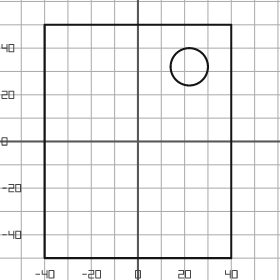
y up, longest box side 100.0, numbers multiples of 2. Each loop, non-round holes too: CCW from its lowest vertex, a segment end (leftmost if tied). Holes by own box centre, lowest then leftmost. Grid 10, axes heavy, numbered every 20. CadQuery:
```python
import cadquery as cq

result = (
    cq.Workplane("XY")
    .moveTo(-40.0, -50.0)
    .lineTo(40.0, -50.0)
    .lineTo(40.0, 50.0)
    .lineTo(-40.0, 50.0)
    .close()
    .moveTo(22.0, 32.0)
    .circle(8.0)
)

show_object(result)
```